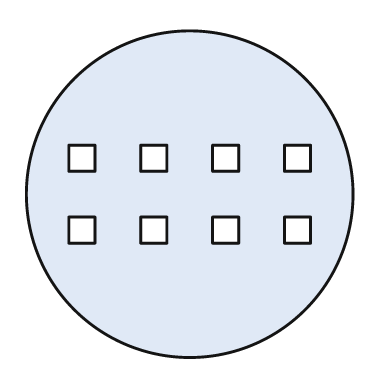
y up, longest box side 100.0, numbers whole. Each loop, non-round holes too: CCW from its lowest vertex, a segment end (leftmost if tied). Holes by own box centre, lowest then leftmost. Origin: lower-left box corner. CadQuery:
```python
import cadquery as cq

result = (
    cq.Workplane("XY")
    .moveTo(50.0, 50.0)
    .circle(50.0)
    .moveTo(13.0, 35.0)
    .lineTo(21.0, 35.0)
    .lineTo(21.0, 43.0)
    .lineTo(13.0, 43.0)
    .close()
    .moveTo(35.0, 35.0)
    .lineTo(43.0, 35.0)
    .lineTo(43.0, 43.0)
    .lineTo(35.0, 43.0)
    .close()
    .moveTo(57.0, 35.0)
    .lineTo(65.0, 35.0)
    .lineTo(65.0, 43.0)
    .lineTo(57.0, 43.0)
    .close()
    .moveTo(79.0, 35.0)
    .lineTo(87.0, 35.0)
    .lineTo(87.0, 43.0)
    .lineTo(79.0, 43.0)
    .close()
    .moveTo(13.0, 57.0)
    .lineTo(21.0, 57.0)
    .lineTo(21.0, 65.0)
    .lineTo(13.0, 65.0)
    .close()
    .moveTo(35.0, 57.0)
    .lineTo(43.0, 57.0)
    .lineTo(43.0, 65.0)
    .lineTo(35.0, 65.0)
    .close()
    .moveTo(57.0, 57.0)
    .lineTo(65.0, 57.0)
    .lineTo(65.0, 65.0)
    .lineTo(57.0, 65.0)
    .close()
    .moveTo(79.0, 57.0)
    .lineTo(87.0, 57.0)
    .lineTo(87.0, 65.0)
    .lineTo(79.0, 65.0)
    .close()
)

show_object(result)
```